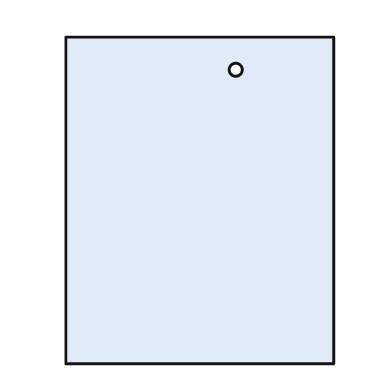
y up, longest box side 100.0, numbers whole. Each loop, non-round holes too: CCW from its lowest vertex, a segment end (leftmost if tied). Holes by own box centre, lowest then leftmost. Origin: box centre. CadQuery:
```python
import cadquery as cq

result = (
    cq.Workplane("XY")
    .moveTo(-41.0, -50.0)
    .lineTo(41.0, -50.0)
    .lineTo(41.0, 50.0)
    .lineTo(-41.0, 50.0)
    .close()
    .moveTo(11.0, 40.0)
    .circle(2.0)
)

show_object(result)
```